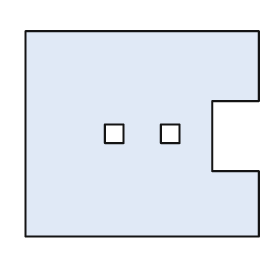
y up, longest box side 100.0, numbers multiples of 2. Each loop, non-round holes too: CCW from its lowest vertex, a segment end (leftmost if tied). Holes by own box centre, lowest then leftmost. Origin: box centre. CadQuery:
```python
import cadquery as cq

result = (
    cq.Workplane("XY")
    .moveTo(-50.0, -44.0)
    .lineTo(50.0, -44.0)
    .lineTo(50.0, -16.0)
    .lineTo(30.0, -16.0)
    .lineTo(30.0, 14.0)
    .lineTo(50.0, 14.0)
    .lineTo(50.0, 44.0)
    .lineTo(-50.0, 44.0)
    .close()
    .moveTo(-16.0, -4.0)
    .lineTo(-8.0, -4.0)
    .lineTo(-8.0, 4.0)
    .lineTo(-16.0, 4.0)
    .close()
    .moveTo(8.0, -4.0)
    .lineTo(16.0, -4.0)
    .lineTo(16.0, 4.0)
    .lineTo(8.0, 4.0)
    .close()
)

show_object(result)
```